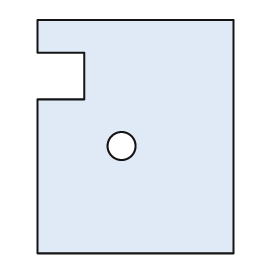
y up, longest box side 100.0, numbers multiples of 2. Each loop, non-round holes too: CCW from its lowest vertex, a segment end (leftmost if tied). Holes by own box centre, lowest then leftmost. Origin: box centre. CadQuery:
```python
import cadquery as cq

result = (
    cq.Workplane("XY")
    .moveTo(-42.0, -50.0)
    .lineTo(42.0, -50.0)
    .lineTo(42.0, 50.0)
    .lineTo(-42.0, 50.0)
    .lineTo(-42.0, 36.0)
    .lineTo(-22.0, 36.0)
    .lineTo(-22.0, 16.0)
    .lineTo(-42.0, 16.0)
    .close()
    .moveTo(-6.0, -4.0)
    .circle(6.0)
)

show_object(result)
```